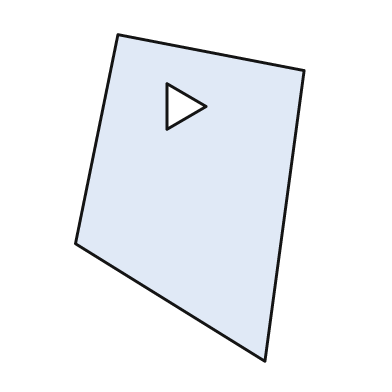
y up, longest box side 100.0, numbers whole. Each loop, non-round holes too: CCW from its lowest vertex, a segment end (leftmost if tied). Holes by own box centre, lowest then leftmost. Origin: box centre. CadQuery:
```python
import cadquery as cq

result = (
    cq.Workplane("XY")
    .moveTo(23.0, -50.0)
    .lineTo(35.0, 39.0)
    .lineTo(-22.0, 50.0)
    .lineTo(-35.0, -14.0)
    .close()
    .moveTo(-7.0, 21.0)
    .lineTo(5.0, 28.0)
    .lineTo(-7.0, 35.0)
    .close()
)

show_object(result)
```